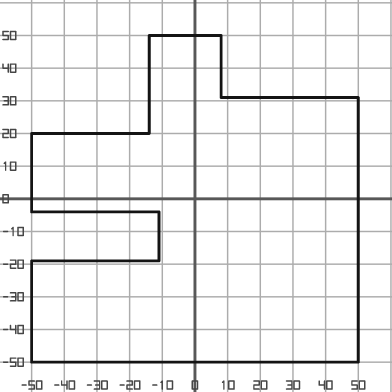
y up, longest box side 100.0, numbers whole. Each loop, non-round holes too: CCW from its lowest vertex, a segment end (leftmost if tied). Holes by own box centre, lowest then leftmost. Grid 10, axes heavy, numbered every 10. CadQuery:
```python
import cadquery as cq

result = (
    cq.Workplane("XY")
    .moveTo(-50.0, -50.0)
    .lineTo(50.0, -50.0)
    .lineTo(50.0, 31.0)
    .lineTo(8.0, 31.0)
    .lineTo(8.0, 50.0)
    .lineTo(-14.0, 50.0)
    .lineTo(-14.0, 20.0)
    .lineTo(-50.0, 20.0)
    .lineTo(-50.0, -4.0)
    .lineTo(-11.0, -4.0)
    .lineTo(-11.0, -19.0)
    .lineTo(-50.0, -19.0)
    .close()
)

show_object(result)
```